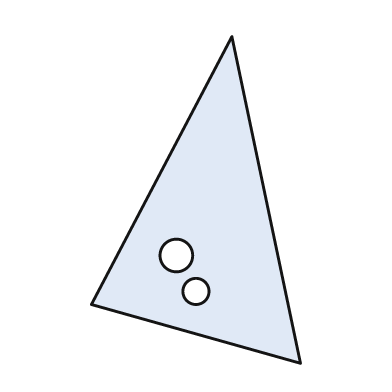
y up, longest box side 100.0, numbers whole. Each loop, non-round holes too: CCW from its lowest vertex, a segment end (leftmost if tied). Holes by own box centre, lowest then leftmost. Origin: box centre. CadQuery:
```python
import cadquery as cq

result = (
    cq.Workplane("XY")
    .moveTo(32.0, -50.0)
    .lineTo(11.0, 50.0)
    .lineTo(-32.0, -32.0)
    .close()
    .moveTo(0.0, -28.0)
    .circle(4.0)
    .moveTo(-6.0, -17.0)
    .circle(5.0)
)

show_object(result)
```